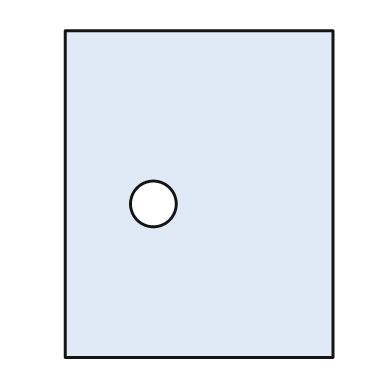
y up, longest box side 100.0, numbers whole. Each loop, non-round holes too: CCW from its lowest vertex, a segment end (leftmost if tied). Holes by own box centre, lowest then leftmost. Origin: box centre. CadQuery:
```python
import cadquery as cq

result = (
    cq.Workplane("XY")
    .moveTo(-41.0, -50.0)
    .lineTo(41.0, -50.0)
    .lineTo(41.0, 50.0)
    .lineTo(-41.0, 50.0)
    .close()
    .moveTo(-14.0, -3.0)
    .circle(7.0)
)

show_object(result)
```